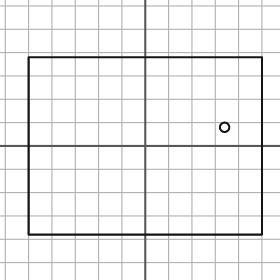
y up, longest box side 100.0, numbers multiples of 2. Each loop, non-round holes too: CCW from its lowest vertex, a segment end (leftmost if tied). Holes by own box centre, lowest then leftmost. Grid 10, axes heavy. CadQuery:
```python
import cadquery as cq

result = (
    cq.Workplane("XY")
    .moveTo(-50.0, -38.0)
    .lineTo(50.0, -38.0)
    .lineTo(50.0, 38.0)
    .lineTo(-50.0, 38.0)
    .close()
    .moveTo(34.0, 8.0)
    .circle(2.0)
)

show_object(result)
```